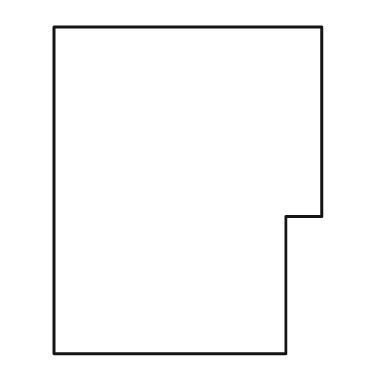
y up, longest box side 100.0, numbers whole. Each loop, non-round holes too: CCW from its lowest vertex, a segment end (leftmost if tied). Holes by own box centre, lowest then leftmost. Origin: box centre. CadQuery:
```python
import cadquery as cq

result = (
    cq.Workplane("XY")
    .moveTo(-41.0, -50.0)
    .lineTo(30.0, -50.0)
    .lineTo(30.0, -8.0)
    .lineTo(41.0, -8.0)
    .lineTo(41.0, 50.0)
    .lineTo(-41.0, 50.0)
    .close()
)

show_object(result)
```